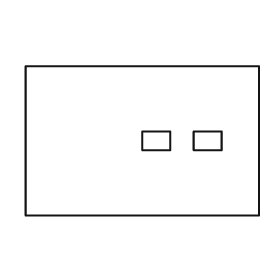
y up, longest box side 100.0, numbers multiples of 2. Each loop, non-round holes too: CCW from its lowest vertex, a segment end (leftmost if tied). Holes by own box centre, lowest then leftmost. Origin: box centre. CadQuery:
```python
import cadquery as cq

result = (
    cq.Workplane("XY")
    .moveTo(-50.0, -32.0)
    .lineTo(50.0, -32.0)
    .lineTo(50.0, 32.0)
    .lineTo(-50.0, 32.0)
    .close()
    .moveTo(0.0, -4.0)
    .lineTo(12.0, -4.0)
    .lineTo(12.0, 4.0)
    .lineTo(0.0, 4.0)
    .close()
    .moveTo(22.0, -4.0)
    .lineTo(34.0, -4.0)
    .lineTo(34.0, 4.0)
    .lineTo(22.0, 4.0)
    .close()
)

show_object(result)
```